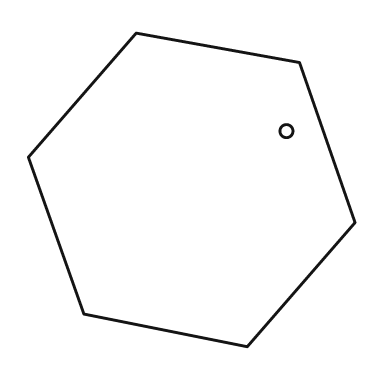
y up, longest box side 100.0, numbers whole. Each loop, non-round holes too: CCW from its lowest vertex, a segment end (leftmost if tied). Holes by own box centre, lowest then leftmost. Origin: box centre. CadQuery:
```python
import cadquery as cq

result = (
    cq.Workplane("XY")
    .moveTo(17.0, -48.0)
    .lineTo(50.0, -10.0)
    .lineTo(33.0, 39.0)
    .lineTo(-17.0, 48.0)
    .lineTo(-50.0, 10.0)
    .lineTo(-33.0, -38.0)
    .close()
    .moveTo(29.0, 18.0)
    .circle(2.0)
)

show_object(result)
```